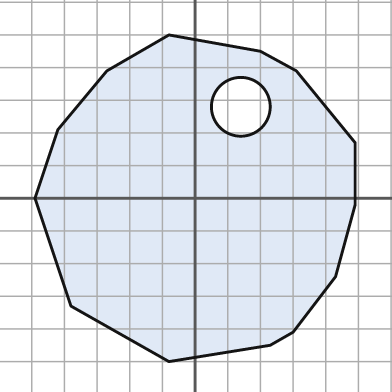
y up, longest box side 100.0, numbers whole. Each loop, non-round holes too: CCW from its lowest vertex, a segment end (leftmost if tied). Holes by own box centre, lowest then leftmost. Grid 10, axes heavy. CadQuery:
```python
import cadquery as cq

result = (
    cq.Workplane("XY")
    .moveTo(-8.0, -50.0)
    .lineTo(23.0, -45.0)
    .lineTo(30.0, -41.0)
    .lineTo(43.0, -24.0)
    .lineTo(49.0, -2.0)
    .lineTo(49.0, 17.0)
    .lineTo(31.0, 39.0)
    .lineTo(20.0, 45.0)
    .lineTo(-8.0, 50.0)
    .lineTo(-27.0, 39.0)
    .lineTo(-42.0, 21.0)
    .lineTo(-49.0, 0.0)
    .lineTo(-38.0, -33.0)
    .close()
    .moveTo(14.0, 28.0)
    .circle(9.0)
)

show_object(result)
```